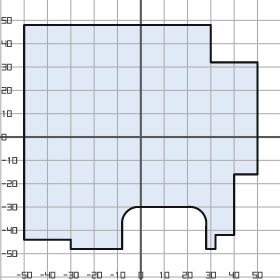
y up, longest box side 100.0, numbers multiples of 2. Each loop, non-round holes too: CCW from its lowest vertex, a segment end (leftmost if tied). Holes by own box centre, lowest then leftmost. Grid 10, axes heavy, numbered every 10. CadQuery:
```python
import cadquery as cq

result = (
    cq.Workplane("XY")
    .moveTo(-30.0, -48.0)
    .lineTo(-8.0, -48.0)
    .lineTo(-8.0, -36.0)
    .threePointArc((-6.0, -32.0), (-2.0, -30.0))
    .lineTo(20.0, -30.0)
    .threePointArc((26.0, -32.0), (28.0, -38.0))
    .lineTo(28.0, -48.0)
    .lineTo(32.0, -48.0)
    .lineTo(32.0, -42.0)
    .lineTo(40.0, -42.0)
    .lineTo(40.0, -16.0)
    .lineTo(50.0, -16.0)
    .lineTo(50.0, 32.0)
    .lineTo(30.0, 32.0)
    .lineTo(30.0, 48.0)
    .lineTo(-50.0, 48.0)
    .lineTo(-50.0, -44.0)
    .lineTo(-30.0, -44.0)
    .close()
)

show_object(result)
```